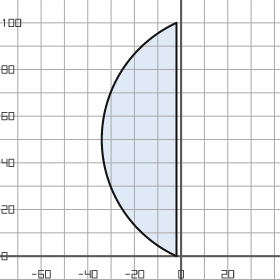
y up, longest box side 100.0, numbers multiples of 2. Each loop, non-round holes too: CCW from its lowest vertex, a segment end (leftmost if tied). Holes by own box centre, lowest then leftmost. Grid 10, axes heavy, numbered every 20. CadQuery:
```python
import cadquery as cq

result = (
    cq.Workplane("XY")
    .moveTo(-2.0, 0.0)
    .lineTo(-2.0, 100.0)
    .threePointArc((-34.0, 50.0), (-2.0, 0.0))
    .close()
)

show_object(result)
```